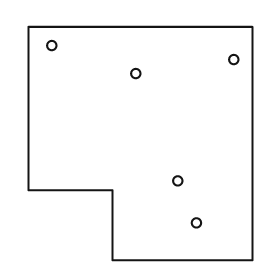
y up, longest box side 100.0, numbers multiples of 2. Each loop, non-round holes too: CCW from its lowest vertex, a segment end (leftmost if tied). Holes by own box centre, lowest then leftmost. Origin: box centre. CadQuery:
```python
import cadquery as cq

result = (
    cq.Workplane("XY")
    .moveTo(-12.0, -50.0)
    .lineTo(48.0, -50.0)
    .lineTo(48.0, 50.0)
    .lineTo(-48.0, 50.0)
    .lineTo(-48.0, -20.0)
    .lineTo(-12.0, -20.0)
    .close()
    .moveTo(24.0, -34.0)
    .circle(2.0)
    .moveTo(16.0, -16.0)
    .circle(2.0)
    .moveTo(-2.0, 30.0)
    .circle(2.0)
    .moveTo(40.0, 36.0)
    .circle(2.0)
    .moveTo(-38.0, 42.0)
    .circle(2.0)
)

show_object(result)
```